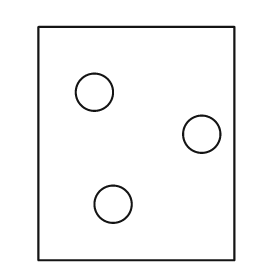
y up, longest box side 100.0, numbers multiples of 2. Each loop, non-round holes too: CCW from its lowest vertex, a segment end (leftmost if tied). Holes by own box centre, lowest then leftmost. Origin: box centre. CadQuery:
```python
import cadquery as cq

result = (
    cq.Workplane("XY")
    .moveTo(-42.0, -50.0)
    .lineTo(42.0, -50.0)
    .lineTo(42.0, 50.0)
    .lineTo(-42.0, 50.0)
    .close()
    .moveTo(-10.0, -26.0)
    .circle(8.0)
    .moveTo(28.0, 4.0)
    .circle(8.0)
    .moveTo(-18.0, 22.0)
    .circle(8.0)
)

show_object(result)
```